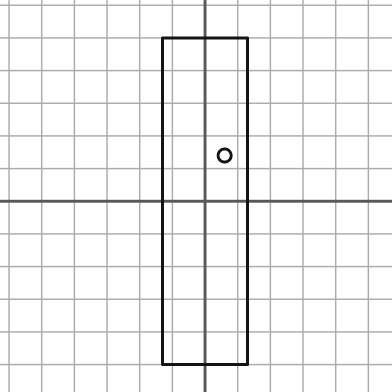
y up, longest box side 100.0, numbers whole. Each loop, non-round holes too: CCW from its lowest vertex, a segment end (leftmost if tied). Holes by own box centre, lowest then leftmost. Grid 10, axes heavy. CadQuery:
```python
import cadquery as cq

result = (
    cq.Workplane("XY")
    .moveTo(-13.0, -50.0)
    .lineTo(13.0, -50.0)
    .lineTo(13.0, 50.0)
    .lineTo(-13.0, 50.0)
    .close()
    .moveTo(6.0, 14.0)
    .circle(2.0)
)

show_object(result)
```